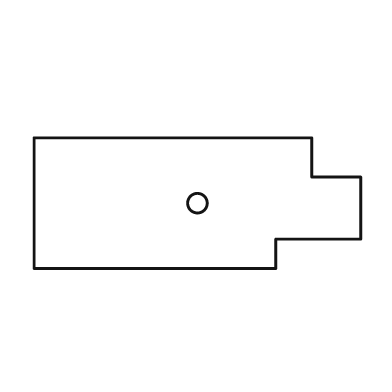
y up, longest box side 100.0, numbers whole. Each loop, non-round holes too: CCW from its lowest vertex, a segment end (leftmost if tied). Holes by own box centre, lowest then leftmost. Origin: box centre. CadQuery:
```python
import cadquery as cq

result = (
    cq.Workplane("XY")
    .moveTo(-50.0, -20.0)
    .lineTo(24.0, -20.0)
    .lineTo(24.0, -11.0)
    .lineTo(50.0, -11.0)
    .lineTo(50.0, 8.0)
    .lineTo(35.0, 8.0)
    .lineTo(35.0, 20.0)
    .lineTo(-50.0, 20.0)
    .close()
    .moveTo(0.0, 0.0)
    .circle(3.0)
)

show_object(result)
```